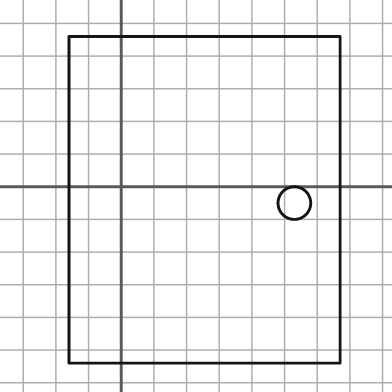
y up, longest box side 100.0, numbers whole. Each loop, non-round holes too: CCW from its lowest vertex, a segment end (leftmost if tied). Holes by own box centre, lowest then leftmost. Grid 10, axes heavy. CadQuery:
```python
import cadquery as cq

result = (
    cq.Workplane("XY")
    .moveTo(-16.0, -54.0)
    .lineTo(67.0, -54.0)
    .lineTo(67.0, 46.0)
    .lineTo(-16.0, 46.0)
    .close()
    .moveTo(53.0, -5.0)
    .circle(5.0)
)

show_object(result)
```